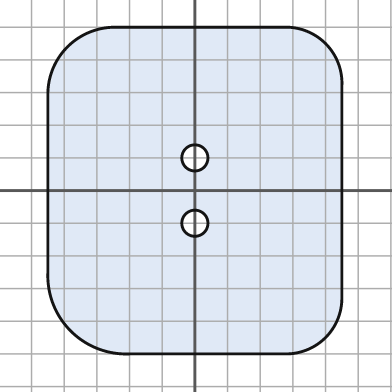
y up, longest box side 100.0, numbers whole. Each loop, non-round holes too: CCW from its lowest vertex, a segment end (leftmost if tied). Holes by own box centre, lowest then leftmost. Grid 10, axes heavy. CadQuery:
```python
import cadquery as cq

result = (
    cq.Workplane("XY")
    .moveTo(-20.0, -50.0)
    .lineTo(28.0, -50.0)
    .threePointArc((40.0, -45.0), (45.0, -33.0))
    .lineTo(45.0, 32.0)
    .threePointArc((40.0, 45.0), (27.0, 50.0))
    .lineTo(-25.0, 50.0)
    .threePointArc((-39.0, 44.0), (-45.0, 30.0))
    .lineTo(-45.0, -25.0)
    .threePointArc((-38.0, -43.0), (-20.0, -50.0))
    .close()
    .moveTo(0.0, -10.0)
    .circle(4.0)
    .moveTo(0.0, 10.0)
    .circle(4.0)
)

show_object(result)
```